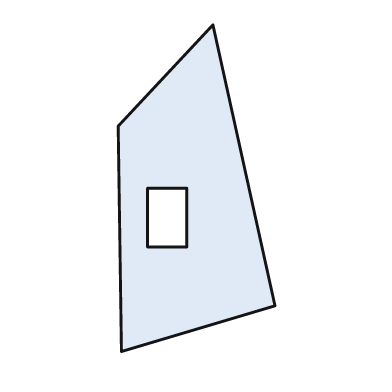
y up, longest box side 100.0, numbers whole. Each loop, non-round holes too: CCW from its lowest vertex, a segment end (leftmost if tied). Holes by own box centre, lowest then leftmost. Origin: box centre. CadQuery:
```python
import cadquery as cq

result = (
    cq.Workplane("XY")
    .moveTo(-23.0, -50.0)
    .lineTo(24.0, -36.0)
    .lineTo(5.0, 50.0)
    .lineTo(-24.0, 19.0)
    .close()
    .moveTo(-15.0, -18.0)
    .lineTo(-3.0, -18.0)
    .lineTo(-3.0, 0.0)
    .lineTo(-15.0, 0.0)
    .close()
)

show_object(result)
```